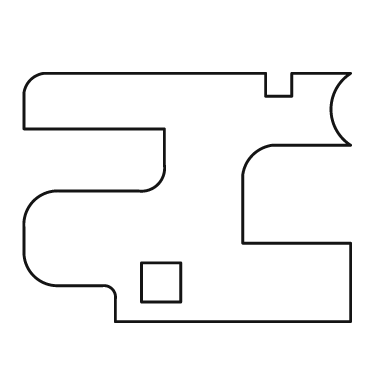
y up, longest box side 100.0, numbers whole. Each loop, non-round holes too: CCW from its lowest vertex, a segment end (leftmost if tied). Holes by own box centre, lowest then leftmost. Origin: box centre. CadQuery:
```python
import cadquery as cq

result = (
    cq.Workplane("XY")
    .moveTo(-22.0, -38.0)
    .lineTo(50.0, -38.0)
    .lineTo(50.0, -14.0)
    .lineTo(17.0, -14.0)
    .lineTo(17.0, 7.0)
    .threePointArc((20.0, 13.0), (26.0, 16.0))
    .lineTo(50.0, 16.0)
    .threePointArc((44.0, 27.0), (50.0, 38.0))
    .lineTo(32.0, 38.0)
    .lineTo(32.0, 31.0)
    .lineTo(24.0, 31.0)
    .lineTo(24.0, 38.0)
    .lineTo(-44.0, 38.0)
    .threePointArc((-48.0, 36.0), (-50.0, 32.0))
    .lineTo(-50.0, 21.0)
    .lineTo(-7.0, 21.0)
    .lineTo(-7.0, 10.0)
    .threePointArc((-9.0, 4.0), (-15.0, 2.0))
    .lineTo(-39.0, 2.0)
    .threePointArc((-47.0, -1.0), (-50.0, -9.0))
    .lineTo(-50.0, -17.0)
    .threePointArc((-47.0, -24.0), (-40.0, -27.0))
    .lineTo(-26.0, -27.0)
    .threePointArc((-23.0, -28.0), (-22.0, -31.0))
    .close()
    .moveTo(-14.0, -32.0)
    .lineTo(-2.0, -32.0)
    .lineTo(-2.0, -20.0)
    .lineTo(-14.0, -20.0)
    .close()
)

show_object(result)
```